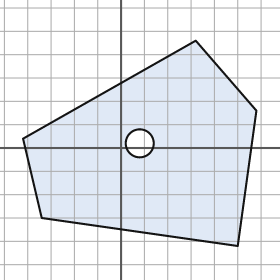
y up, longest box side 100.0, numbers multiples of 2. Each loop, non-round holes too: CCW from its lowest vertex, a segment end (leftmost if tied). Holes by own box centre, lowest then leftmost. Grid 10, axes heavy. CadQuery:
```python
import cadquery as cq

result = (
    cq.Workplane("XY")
    .moveTo(50.0, -42.0)
    .lineTo(58.0, 16.0)
    .lineTo(32.0, 46.0)
    .lineTo(-42.0, 4.0)
    .lineTo(-34.0, -30.0)
    .close()
    .moveTo(8.0, 2.0)
    .circle(6.0)
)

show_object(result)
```